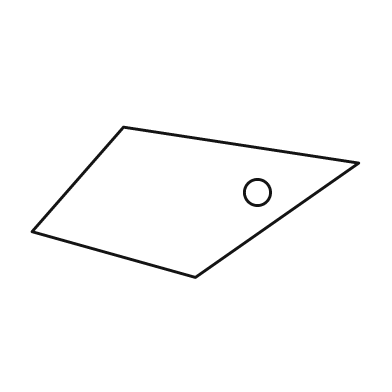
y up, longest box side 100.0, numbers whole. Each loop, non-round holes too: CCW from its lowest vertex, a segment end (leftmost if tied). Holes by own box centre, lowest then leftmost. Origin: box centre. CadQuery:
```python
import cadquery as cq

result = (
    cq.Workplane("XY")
    .moveTo(0.0, -23.0)
    .lineTo(50.0, 12.0)
    .lineTo(-22.0, 23.0)
    .lineTo(-50.0, -9.0)
    .close()
    .moveTo(19.0, 3.0)
    .circle(4.0)
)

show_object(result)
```